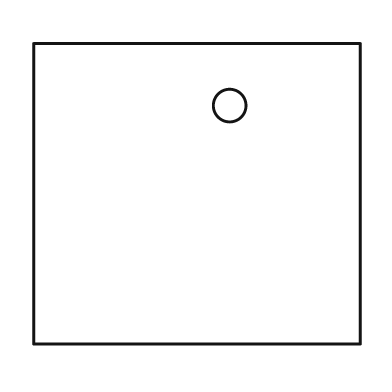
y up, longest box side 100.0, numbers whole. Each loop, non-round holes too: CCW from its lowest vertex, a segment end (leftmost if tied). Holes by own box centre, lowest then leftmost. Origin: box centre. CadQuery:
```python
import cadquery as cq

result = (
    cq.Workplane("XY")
    .moveTo(-50.0, -46.0)
    .lineTo(50.0, -46.0)
    .lineTo(50.0, 46.0)
    .lineTo(-50.0, 46.0)
    .close()
    .moveTo(10.0, 27.0)
    .circle(5.0)
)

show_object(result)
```